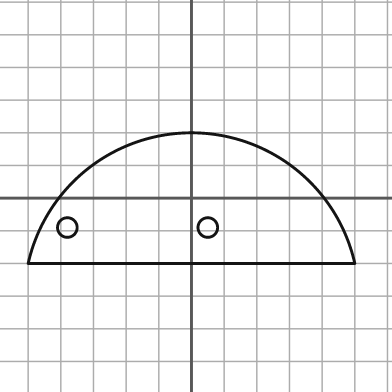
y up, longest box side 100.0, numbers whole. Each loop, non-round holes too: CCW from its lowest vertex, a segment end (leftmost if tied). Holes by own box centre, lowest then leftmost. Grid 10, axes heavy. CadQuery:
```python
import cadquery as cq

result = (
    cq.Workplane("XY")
    .moveTo(-50.0, -20.0)
    .lineTo(50.0, -20.0)
    .threePointArc((0.0, 20.0), (-50.0, -20.0))
    .close()
    .moveTo(-38.0, -9.0)
    .circle(3.0)
    .moveTo(5.0, -9.0)
    .circle(3.0)
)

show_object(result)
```